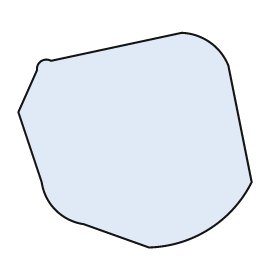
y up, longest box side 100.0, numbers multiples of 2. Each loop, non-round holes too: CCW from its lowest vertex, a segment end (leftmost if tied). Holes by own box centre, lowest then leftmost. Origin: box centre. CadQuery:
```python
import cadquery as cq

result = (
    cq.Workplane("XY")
    .moveTo(6.0, -46.0)
    .threePointArc((32.0, -38.0), (50.0, -18.0))
    .lineTo(40.0, 32.0)
    .threePointArc((32.0, 42.0), (20.0, 46.0))
    .lineTo(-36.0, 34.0)
    .threePointArc((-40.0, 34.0), (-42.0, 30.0))
    .lineTo(-50.0, 12.0)
    .lineTo(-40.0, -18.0)
    .threePointArc((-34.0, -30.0), (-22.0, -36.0))
    .close()
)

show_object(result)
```